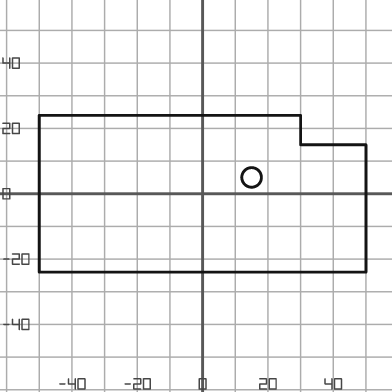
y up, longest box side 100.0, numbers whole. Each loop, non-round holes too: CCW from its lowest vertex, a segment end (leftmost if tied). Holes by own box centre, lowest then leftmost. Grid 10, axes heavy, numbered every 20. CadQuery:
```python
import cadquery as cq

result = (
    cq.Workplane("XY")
    .moveTo(-50.0, -24.0)
    .lineTo(50.0, -24.0)
    .lineTo(50.0, 15.0)
    .lineTo(30.0, 15.0)
    .lineTo(30.0, 24.0)
    .lineTo(-50.0, 24.0)
    .close()
    .moveTo(15.0, 5.0)
    .circle(3.0)
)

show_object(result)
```